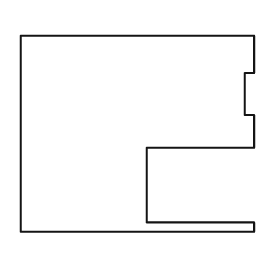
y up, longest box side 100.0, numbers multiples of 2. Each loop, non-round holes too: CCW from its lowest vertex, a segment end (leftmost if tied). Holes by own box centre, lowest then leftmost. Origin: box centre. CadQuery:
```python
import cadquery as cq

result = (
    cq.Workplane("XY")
    .moveTo(-50.0, -42.0)
    .lineTo(50.0, -42.0)
    .lineTo(50.0, -38.0)
    .lineTo(4.0, -38.0)
    .lineTo(4.0, -6.0)
    .lineTo(50.0, -6.0)
    .lineTo(50.0, 8.0)
    .lineTo(46.0, 8.0)
    .lineTo(46.0, 26.0)
    .lineTo(50.0, 26.0)
    .lineTo(50.0, 42.0)
    .lineTo(-50.0, 42.0)
    .close()
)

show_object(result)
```